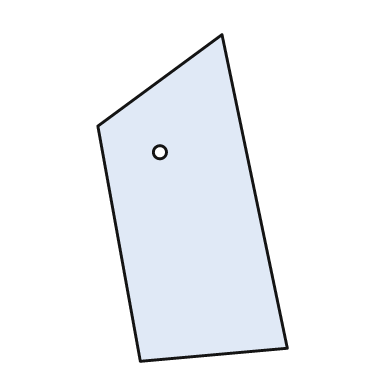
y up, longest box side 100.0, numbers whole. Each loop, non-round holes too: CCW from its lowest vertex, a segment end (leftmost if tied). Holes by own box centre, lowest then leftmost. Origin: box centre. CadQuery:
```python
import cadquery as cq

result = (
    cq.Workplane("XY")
    .moveTo(-16.0, -50.0)
    .lineTo(29.0, -46.0)
    .lineTo(9.0, 50.0)
    .lineTo(-29.0, 22.0)
    .close()
    .moveTo(-10.0, 14.0)
    .circle(2.0)
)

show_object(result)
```